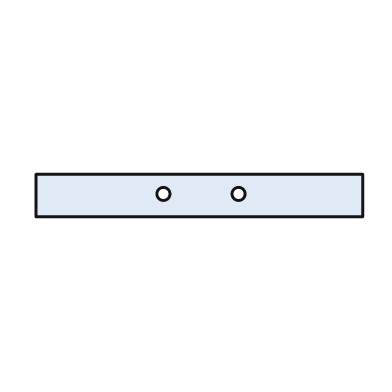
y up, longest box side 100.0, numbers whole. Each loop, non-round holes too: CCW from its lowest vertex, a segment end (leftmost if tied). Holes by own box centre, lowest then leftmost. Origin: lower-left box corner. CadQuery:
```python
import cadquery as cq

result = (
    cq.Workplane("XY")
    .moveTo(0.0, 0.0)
    .lineTo(100.0, 0.0)
    .lineTo(100.0, 13.0)
    .lineTo(0.0, 13.0)
    .close()
    .moveTo(39.0, 7.0)
    .circle(2.0)
    .moveTo(62.0, 7.0)
    .circle(2.0)
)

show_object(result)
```